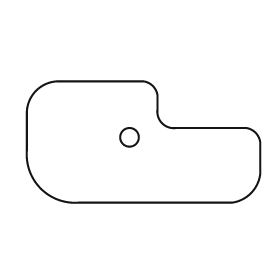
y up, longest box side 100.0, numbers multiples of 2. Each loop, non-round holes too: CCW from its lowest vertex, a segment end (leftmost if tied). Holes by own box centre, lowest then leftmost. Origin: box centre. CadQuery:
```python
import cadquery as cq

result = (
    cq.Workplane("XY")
    .moveTo(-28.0, -26.0)
    .lineTo(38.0, -26.0)
    .threePointArc((46.0, -22.0), (50.0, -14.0))
    .lineTo(50.0, 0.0)
    .threePointArc((48.0, 4.0), (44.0, 6.0))
    .lineTo(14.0, 6.0)
    .threePointArc((8.0, 8.0), (6.0, 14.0))
    .lineTo(6.0, 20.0)
    .threePointArc((4.0, 24.0), (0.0, 26.0))
    .lineTo(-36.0, 26.0)
    .threePointArc((-46.0, 22.0), (-50.0, 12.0))
    .lineTo(-50.0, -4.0)
    .threePointArc((-44.0, -20.0), (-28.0, -26.0))
    .close()
    .moveTo(-6.0, 2.0)
    .circle(4.0)
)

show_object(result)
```